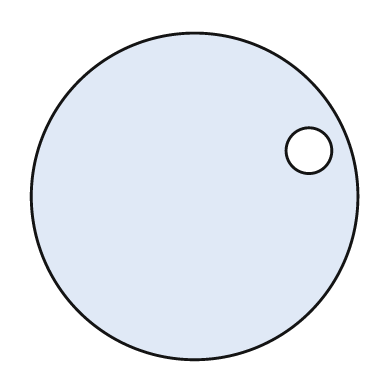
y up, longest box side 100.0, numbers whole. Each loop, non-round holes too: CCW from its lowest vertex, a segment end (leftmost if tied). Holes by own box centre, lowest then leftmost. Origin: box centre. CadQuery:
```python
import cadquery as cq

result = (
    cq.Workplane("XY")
    .moveTo(0.0, 0.0)
    .circle(50.0)
    .moveTo(35.0, 14.0)
    .circle(7.0)
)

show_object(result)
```